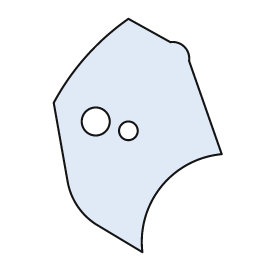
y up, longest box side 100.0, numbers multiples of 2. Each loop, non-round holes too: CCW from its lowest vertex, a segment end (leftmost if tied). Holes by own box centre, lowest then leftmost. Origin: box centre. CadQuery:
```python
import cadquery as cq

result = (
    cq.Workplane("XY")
    .moveTo(2.0, -50.0)
    .threePointArc((10.0, -22.0), (36.0, -8.0))
    .lineTo(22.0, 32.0)
    .threePointArc((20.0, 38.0), (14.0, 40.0))
    .lineTo(-4.0, 50.0)
    .threePointArc((-22.0, 34.0), (-36.0, 14.0))
    .lineTo(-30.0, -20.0)
    .threePointArc((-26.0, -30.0), (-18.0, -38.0))
    .close()
    .moveTo(-4.0, 2.0)
    .circle(4.0)
    .moveTo(-18.0, 6.0)
    .circle(6.0)
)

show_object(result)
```